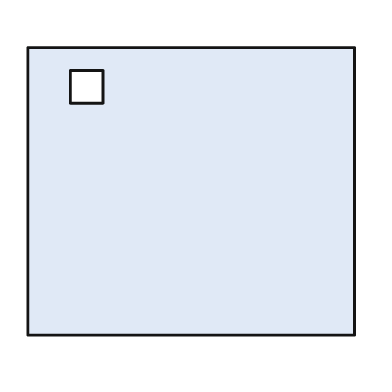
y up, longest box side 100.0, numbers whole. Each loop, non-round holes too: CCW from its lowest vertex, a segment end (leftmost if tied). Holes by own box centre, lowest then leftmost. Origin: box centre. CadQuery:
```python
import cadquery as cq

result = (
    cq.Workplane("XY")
    .moveTo(-50.0, -44.0)
    .lineTo(50.0, -44.0)
    .lineTo(50.0, 44.0)
    .lineTo(-50.0, 44.0)
    .close()
    .moveTo(-37.0, 27.0)
    .lineTo(-27.0, 27.0)
    .lineTo(-27.0, 37.0)
    .lineTo(-37.0, 37.0)
    .close()
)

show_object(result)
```